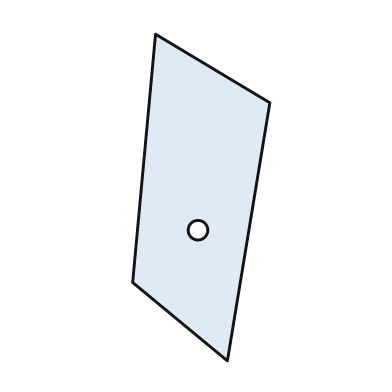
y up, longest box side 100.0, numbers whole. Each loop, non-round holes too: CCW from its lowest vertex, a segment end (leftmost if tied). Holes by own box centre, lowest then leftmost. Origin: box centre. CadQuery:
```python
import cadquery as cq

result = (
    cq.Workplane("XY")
    .moveTo(8.0, -50.0)
    .lineTo(21.0, 29.0)
    .lineTo(-14.0, 50.0)
    .lineTo(-21.0, -26.0)
    .close()
    .moveTo(-1.0, -10.0)
    .circle(3.0)
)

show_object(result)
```